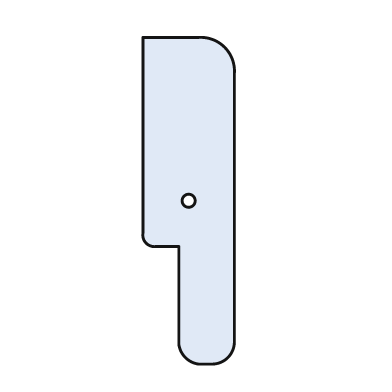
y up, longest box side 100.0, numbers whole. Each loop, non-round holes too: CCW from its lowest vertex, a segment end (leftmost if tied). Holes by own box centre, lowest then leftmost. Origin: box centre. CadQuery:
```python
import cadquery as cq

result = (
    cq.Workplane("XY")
    .moveTo(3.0, -50.0)
    .lineTo(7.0, -50.0)
    .threePointArc((12.0, -48.0), (14.0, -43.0))
    .lineTo(14.0, 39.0)
    .threePointArc((11.0, 47.0), (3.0, 50.0))
    .lineTo(-14.0, 50.0)
    .lineTo(-14.0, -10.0)
    .threePointArc((-13.0, -13.0), (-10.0, -14.0))
    .lineTo(-3.0, -14.0)
    .lineTo(-3.0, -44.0)
    .threePointArc((-1.0, -48.0), (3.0, -50.0))
    .close()
    .moveTo(0.0, 0.0)
    .circle(2.0)
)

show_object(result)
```